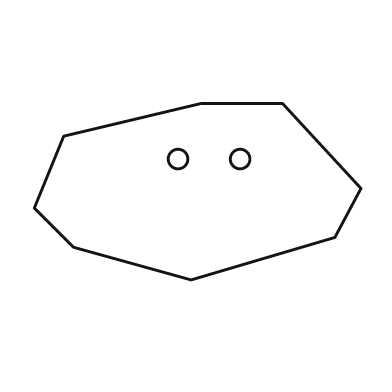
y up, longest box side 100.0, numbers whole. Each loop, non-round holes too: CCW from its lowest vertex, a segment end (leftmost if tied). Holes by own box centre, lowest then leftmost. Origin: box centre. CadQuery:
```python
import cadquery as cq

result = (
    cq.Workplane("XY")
    .moveTo(-2.0, -27.0)
    .lineTo(42.0, -14.0)
    .lineTo(50.0, 1.0)
    .lineTo(26.0, 27.0)
    .lineTo(1.0, 27.0)
    .lineTo(-41.0, 17.0)
    .lineTo(-50.0, -5.0)
    .lineTo(-38.0, -17.0)
    .close()
    .moveTo(-6.0, 10.0)
    .circle(3.0)
    .moveTo(13.0, 10.0)
    .circle(3.0)
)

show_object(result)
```